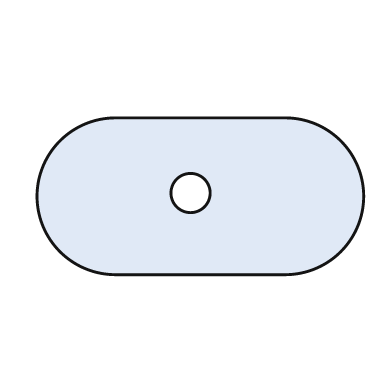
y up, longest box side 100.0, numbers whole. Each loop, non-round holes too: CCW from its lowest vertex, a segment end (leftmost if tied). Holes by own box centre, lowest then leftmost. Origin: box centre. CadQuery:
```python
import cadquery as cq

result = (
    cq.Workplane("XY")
    .moveTo(-26.0, -24.0)
    .lineTo(26.0, -24.0)
    .threePointArc((50.0, 0.0), (26.0, 24.0))
    .lineTo(-26.0, 24.0)
    .threePointArc((-50.0, 0.0), (-26.0, -24.0))
    .close()
    .moveTo(-3.0, 1.0)
    .circle(6.0)
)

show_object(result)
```